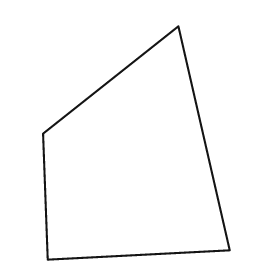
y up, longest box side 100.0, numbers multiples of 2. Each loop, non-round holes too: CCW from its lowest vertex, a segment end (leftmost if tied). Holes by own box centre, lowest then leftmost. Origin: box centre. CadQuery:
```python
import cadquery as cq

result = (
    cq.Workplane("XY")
    .moveTo(-38.0, -50.0)
    .lineTo(40.0, -46.0)
    .lineTo(18.0, 50.0)
    .lineTo(-40.0, 4.0)
    .close()
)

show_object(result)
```